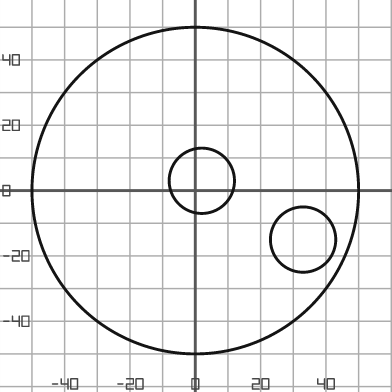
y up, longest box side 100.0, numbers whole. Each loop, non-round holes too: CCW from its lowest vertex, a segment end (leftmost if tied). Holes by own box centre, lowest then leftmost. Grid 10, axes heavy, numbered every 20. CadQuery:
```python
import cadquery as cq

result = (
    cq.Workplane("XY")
    .moveTo(0.0, 0.0)
    .circle(50.0)
    .moveTo(33.0, -15.0)
    .circle(10.0)
    .moveTo(2.0, 3.0)
    .circle(10.0)
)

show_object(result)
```